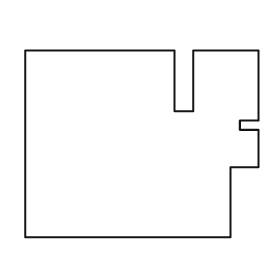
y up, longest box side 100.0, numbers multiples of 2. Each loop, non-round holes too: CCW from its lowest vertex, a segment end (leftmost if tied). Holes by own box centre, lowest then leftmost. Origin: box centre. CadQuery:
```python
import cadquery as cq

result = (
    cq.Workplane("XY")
    .moveTo(-50.0, -40.0)
    .lineTo(38.0, -40.0)
    .lineTo(38.0, -10.0)
    .lineTo(50.0, -10.0)
    .lineTo(50.0, 6.0)
    .lineTo(42.0, 6.0)
    .lineTo(42.0, 10.0)
    .lineTo(50.0, 10.0)
    .lineTo(50.0, 40.0)
    .lineTo(22.0, 40.0)
    .lineTo(22.0, 14.0)
    .lineTo(14.0, 14.0)
    .lineTo(14.0, 40.0)
    .lineTo(-50.0, 40.0)
    .close()
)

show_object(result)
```